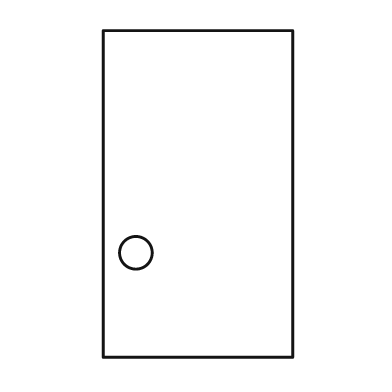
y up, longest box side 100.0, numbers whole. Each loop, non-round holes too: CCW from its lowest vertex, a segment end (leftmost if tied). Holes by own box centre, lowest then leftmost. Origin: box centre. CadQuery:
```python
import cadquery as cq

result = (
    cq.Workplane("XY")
    .moveTo(-29.0, -50.0)
    .lineTo(29.0, -50.0)
    .lineTo(29.0, 50.0)
    .lineTo(-29.0, 50.0)
    .close()
    .moveTo(-19.0, -18.0)
    .circle(5.0)
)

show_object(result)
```